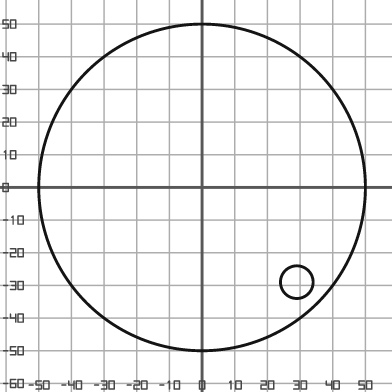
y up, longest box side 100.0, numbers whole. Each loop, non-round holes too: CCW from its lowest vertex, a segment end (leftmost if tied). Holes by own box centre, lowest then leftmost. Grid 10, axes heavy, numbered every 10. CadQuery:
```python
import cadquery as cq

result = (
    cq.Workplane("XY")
    .moveTo(0.0, 0.0)
    .circle(50.0)
    .moveTo(29.0, -29.0)
    .circle(5.0)
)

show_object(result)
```